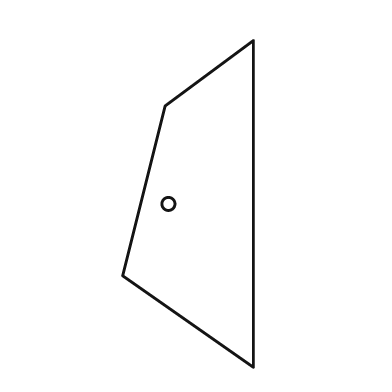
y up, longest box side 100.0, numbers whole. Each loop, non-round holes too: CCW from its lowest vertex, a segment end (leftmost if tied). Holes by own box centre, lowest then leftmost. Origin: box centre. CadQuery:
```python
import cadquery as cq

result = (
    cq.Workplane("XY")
    .moveTo(20.0, -50.0)
    .lineTo(20.0, 50.0)
    .lineTo(-7.0, 30.0)
    .lineTo(-20.0, -22.0)
    .close()
    .moveTo(-6.0, 0.0)
    .circle(2.0)
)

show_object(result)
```